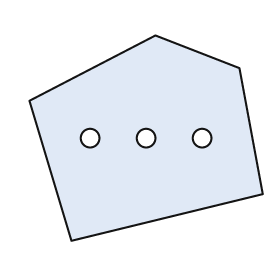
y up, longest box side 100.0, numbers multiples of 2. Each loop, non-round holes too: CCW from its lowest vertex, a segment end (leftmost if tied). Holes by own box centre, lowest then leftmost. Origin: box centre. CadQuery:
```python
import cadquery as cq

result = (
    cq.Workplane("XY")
    .moveTo(-32.0, -44.0)
    .lineTo(50.0, -24.0)
    .lineTo(40.0, 30.0)
    .lineTo(4.0, 44.0)
    .lineTo(-50.0, 16.0)
    .close()
    .moveTo(-24.0, 0.0)
    .circle(4.0)
    .moveTo(0.0, 0.0)
    .circle(4.0)
    .moveTo(24.0, 0.0)
    .circle(4.0)
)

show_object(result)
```